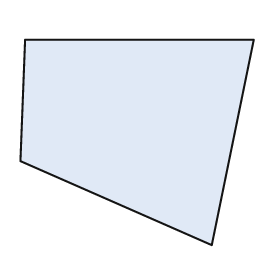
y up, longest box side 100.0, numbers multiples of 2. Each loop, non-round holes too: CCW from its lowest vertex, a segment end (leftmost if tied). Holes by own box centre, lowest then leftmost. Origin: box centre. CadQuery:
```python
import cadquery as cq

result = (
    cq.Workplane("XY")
    .moveTo(32.0, -44.0)
    .lineTo(50.0, 44.0)
    .lineTo(-48.0, 44.0)
    .lineTo(-50.0, -8.0)
    .close()
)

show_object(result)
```